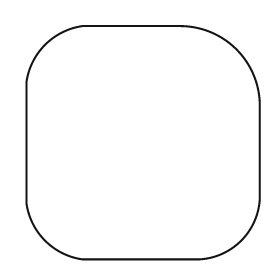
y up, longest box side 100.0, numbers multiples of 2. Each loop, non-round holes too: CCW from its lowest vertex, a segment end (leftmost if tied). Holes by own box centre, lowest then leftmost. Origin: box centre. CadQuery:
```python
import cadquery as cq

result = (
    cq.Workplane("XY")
    .moveTo(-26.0, -50.0)
    .lineTo(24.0, -50.0)
    .threePointArc((42.0, -42.0), (50.0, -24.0))
    .lineTo(50.0, 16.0)
    .threePointArc((40.0, 40.0), (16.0, 50.0))
    .lineTo(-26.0, 50.0)
    .threePointArc((-42.0, 42.0), (-50.0, 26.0))
    .lineTo(-50.0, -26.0)
    .threePointArc((-42.0, -42.0), (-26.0, -50.0))
    .close()
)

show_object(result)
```